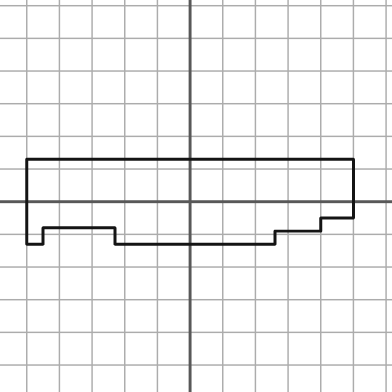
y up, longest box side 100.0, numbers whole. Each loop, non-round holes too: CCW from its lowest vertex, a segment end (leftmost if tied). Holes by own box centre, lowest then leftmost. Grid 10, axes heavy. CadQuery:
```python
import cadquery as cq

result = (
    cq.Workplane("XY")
    .moveTo(-50.0, -13.0)
    .lineTo(-45.0, -13.0)
    .lineTo(-45.0, -8.0)
    .lineTo(-23.0, -8.0)
    .lineTo(-23.0, -13.0)
    .lineTo(26.0, -13.0)
    .lineTo(26.0, -9.0)
    .lineTo(40.0, -9.0)
    .lineTo(40.0, -5.0)
    .lineTo(50.0, -5.0)
    .lineTo(50.0, 13.0)
    .lineTo(-50.0, 13.0)
    .close()
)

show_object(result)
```